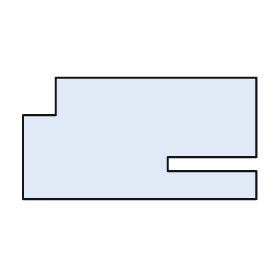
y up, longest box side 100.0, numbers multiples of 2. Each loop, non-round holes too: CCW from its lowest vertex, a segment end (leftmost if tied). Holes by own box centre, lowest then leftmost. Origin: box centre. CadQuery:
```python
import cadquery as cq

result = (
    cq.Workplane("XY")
    .moveTo(-50.0, -26.0)
    .lineTo(50.0, -26.0)
    .lineTo(50.0, -14.0)
    .lineTo(12.0, -14.0)
    .lineTo(12.0, -8.0)
    .lineTo(50.0, -8.0)
    .lineTo(50.0, 26.0)
    .lineTo(-36.0, 26.0)
    .lineTo(-36.0, 10.0)
    .lineTo(-50.0, 10.0)
    .close()
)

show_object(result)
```